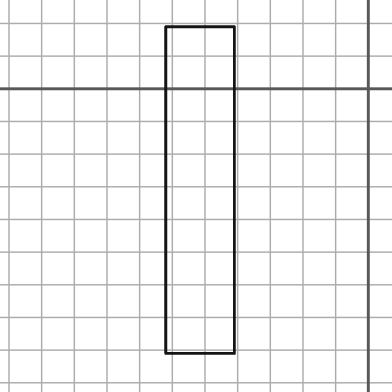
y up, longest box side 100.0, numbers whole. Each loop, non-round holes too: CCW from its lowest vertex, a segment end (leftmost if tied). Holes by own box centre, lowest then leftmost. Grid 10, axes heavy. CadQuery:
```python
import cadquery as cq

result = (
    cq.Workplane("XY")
    .moveTo(-62.0, -81.0)
    .lineTo(-41.0, -81.0)
    .lineTo(-41.0, 19.0)
    .lineTo(-62.0, 19.0)
    .close()
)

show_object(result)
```